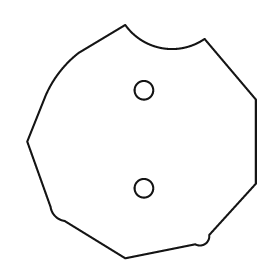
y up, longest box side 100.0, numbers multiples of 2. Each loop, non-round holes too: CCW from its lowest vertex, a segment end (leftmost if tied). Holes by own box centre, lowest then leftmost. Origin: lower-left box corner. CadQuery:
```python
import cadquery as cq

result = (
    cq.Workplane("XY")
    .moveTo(42.0, 0.0)
    .lineTo(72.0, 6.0)
    .threePointArc((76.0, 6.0), (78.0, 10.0))
    .lineTo(98.0, 32.0)
    .lineTo(98.0, 68.0)
    .lineTo(76.0, 94.0)
    .threePointArc((58.0, 90.0), (42.0, 100.0))
    .lineTo(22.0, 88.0)
    .threePointArc((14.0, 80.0), (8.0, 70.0))
    .lineTo(0.0, 50.0)
    .lineTo(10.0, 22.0)
    .threePointArc((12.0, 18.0), (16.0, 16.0))
    .close()
    .moveTo(50.0, 30.0)
    .circle(4.0)
    .moveTo(50.0, 72.0)
    .circle(4.0)
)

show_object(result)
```